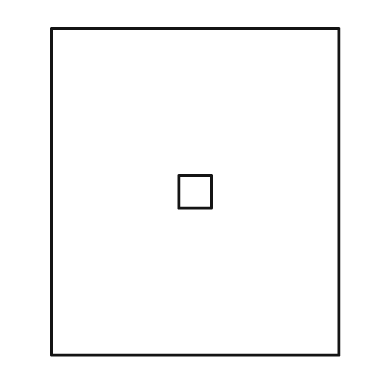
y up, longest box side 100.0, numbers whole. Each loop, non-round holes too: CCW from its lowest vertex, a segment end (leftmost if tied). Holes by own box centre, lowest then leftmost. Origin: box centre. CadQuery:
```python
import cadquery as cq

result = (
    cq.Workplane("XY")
    .moveTo(-44.0, -50.0)
    .lineTo(44.0, -50.0)
    .lineTo(44.0, 50.0)
    .lineTo(-44.0, 50.0)
    .close()
    .moveTo(-5.0, -5.0)
    .lineTo(5.0, -5.0)
    .lineTo(5.0, 5.0)
    .lineTo(-5.0, 5.0)
    .close()
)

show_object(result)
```